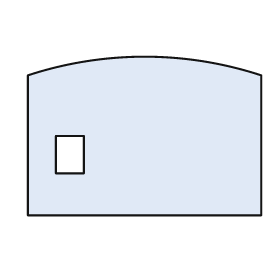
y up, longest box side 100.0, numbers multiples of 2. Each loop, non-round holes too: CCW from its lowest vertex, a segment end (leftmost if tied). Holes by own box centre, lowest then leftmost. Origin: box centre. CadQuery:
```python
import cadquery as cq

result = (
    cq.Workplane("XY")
    .moveTo(-50.0, -34.0)
    .lineTo(50.0, -34.0)
    .lineTo(50.0, 26.0)
    .threePointArc((0.0, 34.0), (-50.0, 26.0))
    .close()
    .moveTo(-38.0, -16.0)
    .lineTo(-26.0, -16.0)
    .lineTo(-26.0, 0.0)
    .lineTo(-38.0, 0.0)
    .close()
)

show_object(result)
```